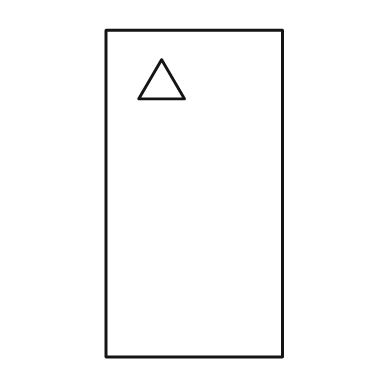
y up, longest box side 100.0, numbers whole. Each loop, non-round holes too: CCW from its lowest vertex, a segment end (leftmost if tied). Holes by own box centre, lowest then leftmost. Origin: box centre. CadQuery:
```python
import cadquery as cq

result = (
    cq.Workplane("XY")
    .moveTo(-27.0, -50.0)
    .lineTo(27.0, -50.0)
    .lineTo(27.0, 50.0)
    .lineTo(-27.0, 50.0)
    .close()
    .moveTo(-17.0, 29.0)
    .lineTo(-3.0, 29.0)
    .lineTo(-10.0, 41.0)
    .close()
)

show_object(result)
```